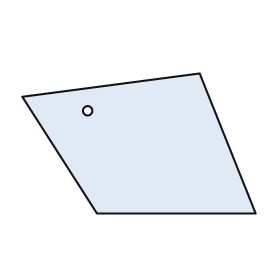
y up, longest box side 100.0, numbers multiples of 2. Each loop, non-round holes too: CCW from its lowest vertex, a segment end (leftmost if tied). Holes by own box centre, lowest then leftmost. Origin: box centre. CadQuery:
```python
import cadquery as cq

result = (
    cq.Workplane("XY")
    .moveTo(-18.0, -30.0)
    .lineTo(50.0, -30.0)
    .lineTo(26.0, 30.0)
    .lineTo(-50.0, 20.0)
    .close()
    .moveTo(-22.0, 14.0)
    .circle(2.0)
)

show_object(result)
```